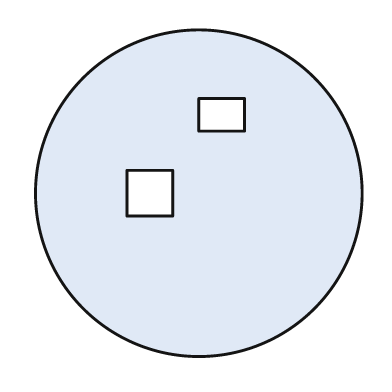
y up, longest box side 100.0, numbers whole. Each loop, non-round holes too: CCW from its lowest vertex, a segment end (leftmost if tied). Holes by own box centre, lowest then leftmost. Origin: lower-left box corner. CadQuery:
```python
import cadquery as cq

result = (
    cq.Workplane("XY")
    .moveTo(50.0, 50.0)
    .circle(50.0)
    .moveTo(28.0, 43.0)
    .lineTo(42.0, 43.0)
    .lineTo(42.0, 57.0)
    .lineTo(28.0, 57.0)
    .close()
    .moveTo(50.0, 69.0)
    .lineTo(64.0, 69.0)
    .lineTo(64.0, 79.0)
    .lineTo(50.0, 79.0)
    .close()
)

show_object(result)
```